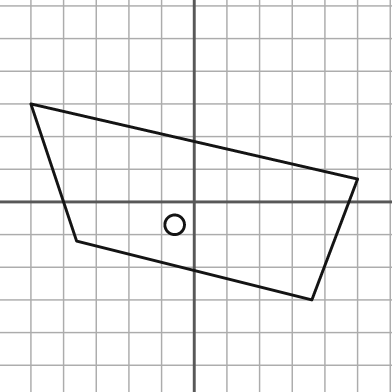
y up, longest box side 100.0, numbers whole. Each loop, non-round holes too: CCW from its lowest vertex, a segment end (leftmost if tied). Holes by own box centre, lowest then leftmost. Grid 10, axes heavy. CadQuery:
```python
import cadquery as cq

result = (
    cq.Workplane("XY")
    .moveTo(36.0, -30.0)
    .lineTo(50.0, 7.0)
    .lineTo(-50.0, 30.0)
    .lineTo(-36.0, -12.0)
    .close()
    .moveTo(-6.0, -7.0)
    .circle(3.0)
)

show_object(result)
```